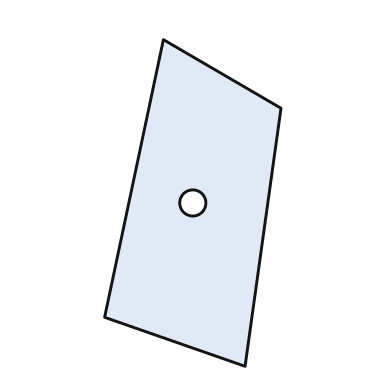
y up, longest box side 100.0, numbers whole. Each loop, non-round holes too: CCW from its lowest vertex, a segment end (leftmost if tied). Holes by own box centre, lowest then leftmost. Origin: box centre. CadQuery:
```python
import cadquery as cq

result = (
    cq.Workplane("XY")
    .moveTo(16.0, -50.0)
    .lineTo(27.0, 29.0)
    .lineTo(-9.0, 50.0)
    .lineTo(-27.0, -35.0)
    .close()
    .moveTo(0.0, 0.0)
    .circle(4.0)
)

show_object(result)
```